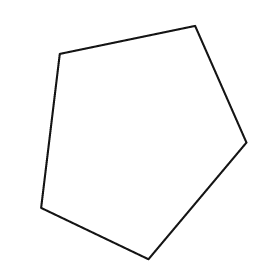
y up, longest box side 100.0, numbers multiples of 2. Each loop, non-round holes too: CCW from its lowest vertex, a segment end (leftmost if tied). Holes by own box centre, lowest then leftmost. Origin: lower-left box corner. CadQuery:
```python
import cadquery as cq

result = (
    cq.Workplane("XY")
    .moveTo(46.0, 0.0)
    .lineTo(88.0, 50.0)
    .lineTo(66.0, 100.0)
    .lineTo(8.0, 88.0)
    .lineTo(0.0, 22.0)
    .close()
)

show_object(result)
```